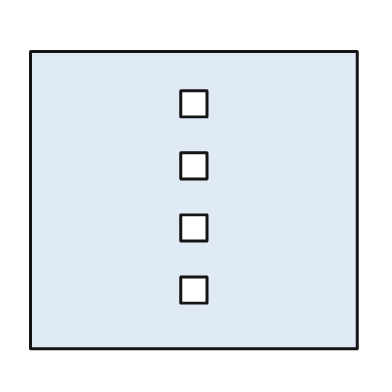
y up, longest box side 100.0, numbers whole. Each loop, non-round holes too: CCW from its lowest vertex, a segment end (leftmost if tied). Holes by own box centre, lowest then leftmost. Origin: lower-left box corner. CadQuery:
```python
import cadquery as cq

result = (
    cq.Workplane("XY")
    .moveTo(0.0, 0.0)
    .lineTo(100.0, 0.0)
    .lineTo(100.0, 91.0)
    .lineTo(0.0, 91.0)
    .close()
    .moveTo(46.0, 14.0)
    .lineTo(54.0, 14.0)
    .lineTo(54.0, 22.0)
    .lineTo(46.0, 22.0)
    .close()
    .moveTo(46.0, 33.0)
    .lineTo(54.0, 33.0)
    .lineTo(54.0, 41.0)
    .lineTo(46.0, 41.0)
    .close()
    .moveTo(46.0, 52.0)
    .lineTo(54.0, 52.0)
    .lineTo(54.0, 60.0)
    .lineTo(46.0, 60.0)
    .close()
    .moveTo(46.0, 71.0)
    .lineTo(54.0, 71.0)
    .lineTo(54.0, 79.0)
    .lineTo(46.0, 79.0)
    .close()
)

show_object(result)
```